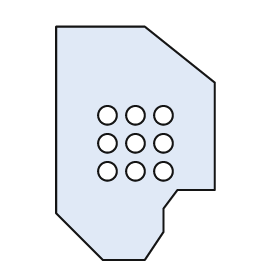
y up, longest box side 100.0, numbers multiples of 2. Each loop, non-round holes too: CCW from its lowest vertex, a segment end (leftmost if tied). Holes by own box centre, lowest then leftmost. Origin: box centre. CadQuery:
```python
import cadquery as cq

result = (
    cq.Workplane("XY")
    .moveTo(-14.0, -50.0)
    .lineTo(4.0, -50.0)
    .lineTo(12.0, -38.0)
    .lineTo(12.0, -28.0)
    .lineTo(18.0, -20.0)
    .lineTo(34.0, -20.0)
    .lineTo(34.0, 26.0)
    .lineTo(4.0, 50.0)
    .lineTo(-34.0, 50.0)
    .lineTo(-34.0, -30.0)
    .close()
    .moveTo(-12.0, -12.0)
    .circle(4.0)
    .moveTo(0.0, -12.0)
    .circle(4.0)
    .moveTo(12.0, -12.0)
    .circle(4.0)
    .moveTo(-12.0, 0.0)
    .circle(4.0)
    .moveTo(0.0, 0.0)
    .circle(4.0)
    .moveTo(12.0, 0.0)
    .circle(4.0)
    .moveTo(-12.0, 12.0)
    .circle(4.0)
    .moveTo(0.0, 12.0)
    .circle(4.0)
    .moveTo(12.0, 12.0)
    .circle(4.0)
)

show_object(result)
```